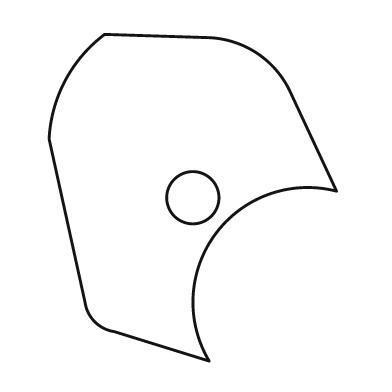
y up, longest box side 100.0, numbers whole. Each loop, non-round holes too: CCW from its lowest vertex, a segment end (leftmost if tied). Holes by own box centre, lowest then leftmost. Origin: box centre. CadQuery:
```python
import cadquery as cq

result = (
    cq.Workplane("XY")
    .moveTo(5.0, -50.0)
    .threePointArc((7.0, -11.0), (44.0, 2.0))
    .lineTo(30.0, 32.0)
    .threePointArc((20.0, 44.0), (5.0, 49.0))
    .lineTo(-27.0, 50.0)
    .threePointArc((-39.0, 36.0), (-44.0, 18.0))
    .lineTo(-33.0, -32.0)
    .threePointArc((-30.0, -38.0), (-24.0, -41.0))
    .close()
    .moveTo(0.0, 0.0)
    .circle(8.0)
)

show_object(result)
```